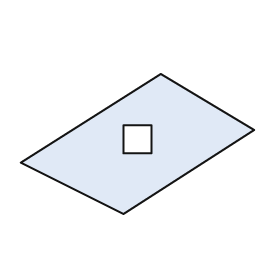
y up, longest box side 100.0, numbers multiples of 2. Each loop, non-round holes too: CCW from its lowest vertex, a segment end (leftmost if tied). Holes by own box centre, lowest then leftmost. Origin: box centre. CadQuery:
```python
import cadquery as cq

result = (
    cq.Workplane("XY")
    .moveTo(-6.0, -30.0)
    .lineTo(50.0, 6.0)
    .lineTo(10.0, 30.0)
    .lineTo(-50.0, -8.0)
    .close()
    .moveTo(-6.0, -4.0)
    .lineTo(6.0, -4.0)
    .lineTo(6.0, 8.0)
    .lineTo(-6.0, 8.0)
    .close()
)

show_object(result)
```